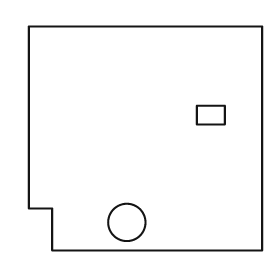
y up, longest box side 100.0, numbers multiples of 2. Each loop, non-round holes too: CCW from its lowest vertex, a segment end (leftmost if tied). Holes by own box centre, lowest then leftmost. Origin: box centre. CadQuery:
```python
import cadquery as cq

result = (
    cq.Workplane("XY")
    .moveTo(-40.0, -48.0)
    .lineTo(50.0, -48.0)
    .lineTo(50.0, 48.0)
    .lineTo(-50.0, 48.0)
    .lineTo(-50.0, -30.0)
    .lineTo(-40.0, -30.0)
    .close()
    .moveTo(-8.0, -36.0)
    .circle(8.0)
    .moveTo(22.0, 6.0)
    .lineTo(34.0, 6.0)
    .lineTo(34.0, 14.0)
    .lineTo(22.0, 14.0)
    .close()
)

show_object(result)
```